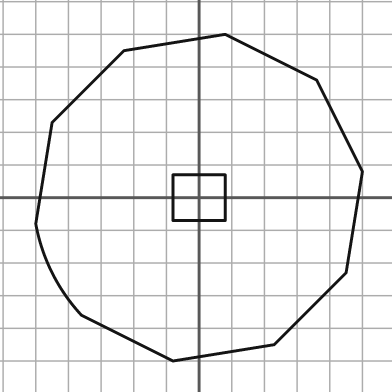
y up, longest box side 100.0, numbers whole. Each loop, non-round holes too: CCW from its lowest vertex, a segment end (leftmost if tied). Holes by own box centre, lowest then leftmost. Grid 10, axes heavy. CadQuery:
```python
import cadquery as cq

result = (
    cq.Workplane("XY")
    .moveTo(-8.0, -50.0)
    .lineTo(23.0, -45.0)
    .lineTo(45.0, -23.0)
    .lineTo(50.0, 8.0)
    .lineTo(36.0, 36.0)
    .lineTo(8.0, 50.0)
    .lineTo(-23.0, 45.0)
    .lineTo(-45.0, 23.0)
    .lineTo(-50.0, -8.0)
    .threePointArc((-45.0, -23.0), (-36.0, -36.0))
    .close()
    .moveTo(-8.0, -7.0)
    .lineTo(8.0, -7.0)
    .lineTo(8.0, 7.0)
    .lineTo(-8.0, 7.0)
    .close()
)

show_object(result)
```